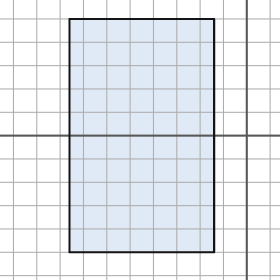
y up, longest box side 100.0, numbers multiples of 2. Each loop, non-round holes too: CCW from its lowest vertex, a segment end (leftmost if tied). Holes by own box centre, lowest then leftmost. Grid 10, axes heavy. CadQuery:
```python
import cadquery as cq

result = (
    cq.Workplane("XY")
    .moveTo(-76.0, -50.0)
    .lineTo(-14.0, -50.0)
    .lineTo(-14.0, 50.0)
    .lineTo(-76.0, 50.0)
    .close()
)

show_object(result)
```